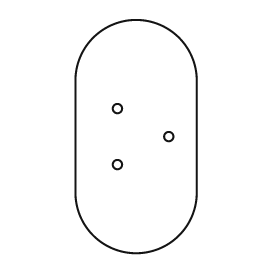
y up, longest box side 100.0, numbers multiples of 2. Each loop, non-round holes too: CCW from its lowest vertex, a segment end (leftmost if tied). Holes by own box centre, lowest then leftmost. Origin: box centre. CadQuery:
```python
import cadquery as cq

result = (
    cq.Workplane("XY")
    .moveTo(-26.0, -24.0)
    .threePointArc((0.0, -50.0), (26.0, -24.0))
    .lineTo(26.0, 24.0)
    .threePointArc((0.0, 50.0), (-26.0, 24.0))
    .close()
    .moveTo(-8.0, -12.0)
    .circle(2.0)
    .moveTo(14.0, 0.0)
    .circle(2.0)
    .moveTo(-8.0, 12.0)
    .circle(2.0)
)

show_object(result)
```